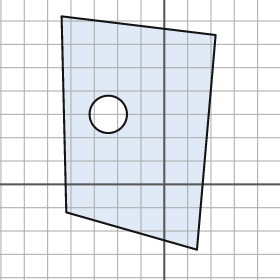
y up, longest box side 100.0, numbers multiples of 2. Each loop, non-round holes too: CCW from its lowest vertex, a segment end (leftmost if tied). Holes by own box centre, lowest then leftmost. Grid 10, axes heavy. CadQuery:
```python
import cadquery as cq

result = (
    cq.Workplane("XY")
    .moveTo(14.0, -28.0)
    .lineTo(22.0, 64.0)
    .lineTo(-44.0, 72.0)
    .lineTo(-42.0, -12.0)
    .close()
    .moveTo(-24.0, 30.0)
    .circle(8.0)
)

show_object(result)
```